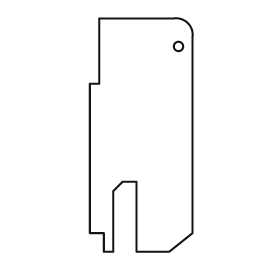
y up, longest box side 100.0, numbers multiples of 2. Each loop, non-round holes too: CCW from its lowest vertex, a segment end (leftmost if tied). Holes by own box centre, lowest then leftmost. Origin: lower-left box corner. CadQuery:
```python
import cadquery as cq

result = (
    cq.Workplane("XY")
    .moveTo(6.0, 0.0)
    .lineTo(10.0, 0.0)
    .lineTo(10.0, 26.0)
    .lineTo(14.0, 30.0)
    .lineTo(20.0, 30.0)
    .lineTo(20.0, 0.0)
    .lineTo(34.0, 0.0)
    .lineTo(44.0, 8.0)
    .lineTo(44.0, 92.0)
    .threePointArc((42.0, 98.0), (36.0, 100.0))
    .lineTo(4.0, 100.0)
    .lineTo(4.0, 72.0)
    .lineTo(0.0, 72.0)
    .lineTo(0.0, 8.0)
    .lineTo(6.0, 8.0)
    .close()
    .moveTo(38.0, 88.0)
    .circle(2.0)
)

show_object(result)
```